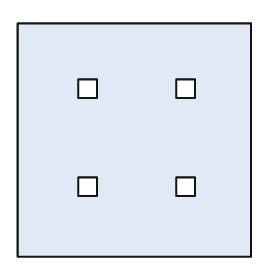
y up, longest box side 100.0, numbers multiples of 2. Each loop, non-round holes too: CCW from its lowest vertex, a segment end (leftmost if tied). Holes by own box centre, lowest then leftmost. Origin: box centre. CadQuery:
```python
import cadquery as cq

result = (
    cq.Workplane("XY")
    .moveTo(-50.0, -50.0)
    .lineTo(50.0, -50.0)
    .lineTo(50.0, 50.0)
    .lineTo(-50.0, 50.0)
    .close()
    .moveTo(-24.0, -24.0)
    .lineTo(-16.0, -24.0)
    .lineTo(-16.0, -16.0)
    .lineTo(-24.0, -16.0)
    .close()
    .moveTo(18.0, -24.0)
    .lineTo(26.0, -24.0)
    .lineTo(26.0, -16.0)
    .lineTo(18.0, -16.0)
    .close()
    .moveTo(-24.0, 18.0)
    .lineTo(-16.0, 18.0)
    .lineTo(-16.0, 26.0)
    .lineTo(-24.0, 26.0)
    .close()
    .moveTo(18.0, 18.0)
    .lineTo(26.0, 18.0)
    .lineTo(26.0, 26.0)
    .lineTo(18.0, 26.0)
    .close()
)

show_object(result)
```